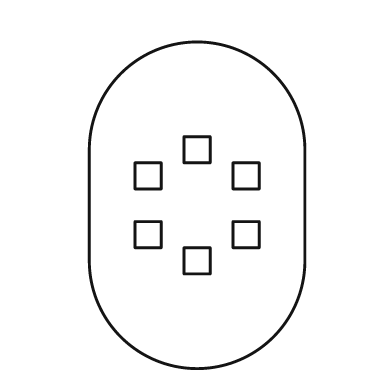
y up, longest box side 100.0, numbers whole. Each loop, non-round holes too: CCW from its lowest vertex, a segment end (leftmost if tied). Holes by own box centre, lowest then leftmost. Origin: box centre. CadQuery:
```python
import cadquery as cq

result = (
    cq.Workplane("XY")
    .moveTo(-33.0, -17.0)
    .threePointArc((0.0, -50.0), (33.0, -17.0))
    .lineTo(33.0, 17.0)
    .threePointArc((0.0, 50.0), (-33.0, 17.0))
    .close()
    .moveTo(-4.0, -21.0)
    .lineTo(4.0, -21.0)
    .lineTo(4.0, -13.0)
    .lineTo(-4.0, -13.0)
    .close()
    .moveTo(-19.0, -13.0)
    .lineTo(-11.0, -13.0)
    .lineTo(-11.0, -5.0)
    .lineTo(-19.0, -5.0)
    .close()
    .moveTo(11.0, -13.0)
    .lineTo(19.0, -13.0)
    .lineTo(19.0, -5.0)
    .lineTo(11.0, -5.0)
    .close()
    .moveTo(-19.0, 5.0)
    .lineTo(-11.0, 5.0)
    .lineTo(-11.0, 13.0)
    .lineTo(-19.0, 13.0)
    .close()
    .moveTo(11.0, 5.0)
    .lineTo(19.0, 5.0)
    .lineTo(19.0, 13.0)
    .lineTo(11.0, 13.0)
    .close()
    .moveTo(-4.0, 13.0)
    .lineTo(4.0, 13.0)
    .lineTo(4.0, 21.0)
    .lineTo(-4.0, 21.0)
    .close()
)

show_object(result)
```